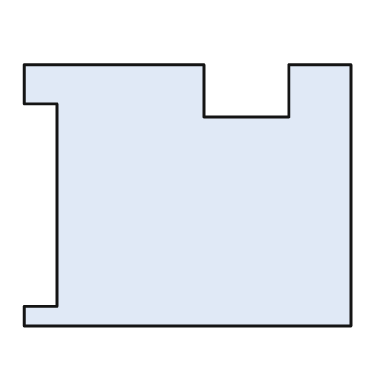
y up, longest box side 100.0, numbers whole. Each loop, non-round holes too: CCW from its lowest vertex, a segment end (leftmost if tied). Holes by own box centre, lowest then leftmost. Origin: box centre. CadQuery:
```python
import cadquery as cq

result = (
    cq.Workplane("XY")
    .moveTo(-50.0, -40.0)
    .lineTo(50.0, -40.0)
    .lineTo(50.0, 40.0)
    .lineTo(31.0, 40.0)
    .lineTo(31.0, 24.0)
    .lineTo(5.0, 24.0)
    .lineTo(5.0, 40.0)
    .lineTo(-50.0, 40.0)
    .lineTo(-50.0, 28.0)
    .lineTo(-40.0, 28.0)
    .lineTo(-40.0, -34.0)
    .lineTo(-50.0, -34.0)
    .close()
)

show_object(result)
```